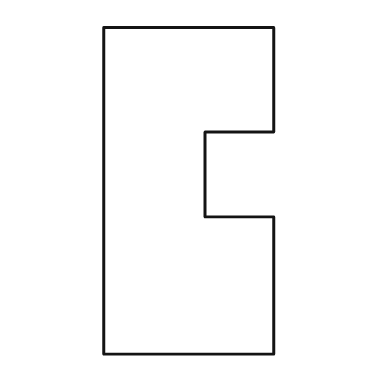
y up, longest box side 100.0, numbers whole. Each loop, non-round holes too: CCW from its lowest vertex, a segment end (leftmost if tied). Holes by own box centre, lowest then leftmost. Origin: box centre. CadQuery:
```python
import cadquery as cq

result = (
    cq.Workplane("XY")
    .moveTo(-26.0, -50.0)
    .lineTo(26.0, -50.0)
    .lineTo(26.0, -8.0)
    .lineTo(5.0, -8.0)
    .lineTo(5.0, 18.0)
    .lineTo(26.0, 18.0)
    .lineTo(26.0, 50.0)
    .lineTo(-26.0, 50.0)
    .close()
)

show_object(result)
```